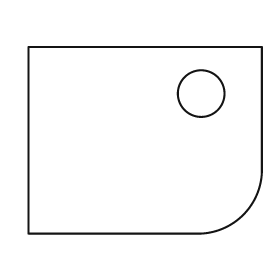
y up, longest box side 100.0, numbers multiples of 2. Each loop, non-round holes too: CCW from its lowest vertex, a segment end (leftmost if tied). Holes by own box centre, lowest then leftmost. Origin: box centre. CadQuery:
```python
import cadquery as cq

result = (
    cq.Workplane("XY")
    .moveTo(-50.0, -40.0)
    .lineTo(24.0, -40.0)
    .threePointArc((42.0, -32.0), (50.0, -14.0))
    .lineTo(50.0, 40.0)
    .lineTo(-50.0, 40.0)
    .close()
    .moveTo(24.0, 20.0)
    .circle(10.0)
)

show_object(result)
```